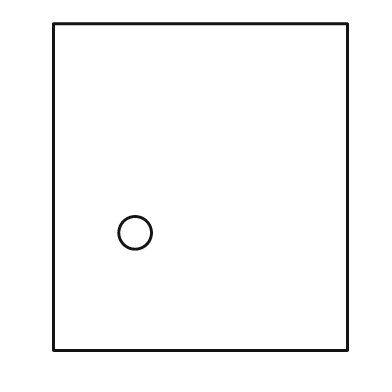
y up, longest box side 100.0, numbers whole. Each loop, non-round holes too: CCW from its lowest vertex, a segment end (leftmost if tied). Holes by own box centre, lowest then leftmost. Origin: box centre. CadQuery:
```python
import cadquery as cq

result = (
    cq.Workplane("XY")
    .moveTo(-45.0, -50.0)
    .lineTo(45.0, -50.0)
    .lineTo(45.0, 50.0)
    .lineTo(-45.0, 50.0)
    .close()
    .moveTo(-20.0, -14.0)
    .circle(5.0)
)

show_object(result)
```